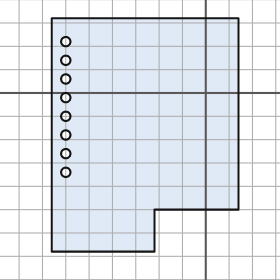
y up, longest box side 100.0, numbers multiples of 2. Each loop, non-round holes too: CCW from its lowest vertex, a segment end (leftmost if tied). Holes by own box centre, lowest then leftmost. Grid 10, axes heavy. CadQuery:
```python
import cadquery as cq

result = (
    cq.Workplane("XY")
    .moveTo(-66.0, -68.0)
    .lineTo(-22.0, -68.0)
    .lineTo(-22.0, -50.0)
    .lineTo(14.0, -50.0)
    .lineTo(14.0, 32.0)
    .lineTo(-66.0, 32.0)
    .close()
    .moveTo(-60.0, -34.0)
    .circle(2.0)
    .moveTo(-60.0, -26.0)
    .circle(2.0)
    .moveTo(-60.0, -18.0)
    .circle(2.0)
    .moveTo(-60.0, -10.0)
    .circle(2.0)
    .moveTo(-60.0, -2.0)
    .circle(2.0)
    .moveTo(-60.0, 6.0)
    .circle(2.0)
    .moveTo(-60.0, 14.0)
    .circle(2.0)
    .moveTo(-60.0, 22.0)
    .circle(2.0)
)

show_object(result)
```